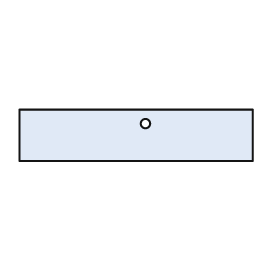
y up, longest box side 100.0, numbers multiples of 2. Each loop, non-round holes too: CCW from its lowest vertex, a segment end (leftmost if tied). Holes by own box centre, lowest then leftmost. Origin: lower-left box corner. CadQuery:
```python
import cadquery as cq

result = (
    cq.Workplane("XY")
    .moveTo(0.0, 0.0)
    .lineTo(100.0, 0.0)
    .lineTo(100.0, 22.0)
    .lineTo(0.0, 22.0)
    .close()
    .moveTo(54.0, 16.0)
    .circle(2.0)
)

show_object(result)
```